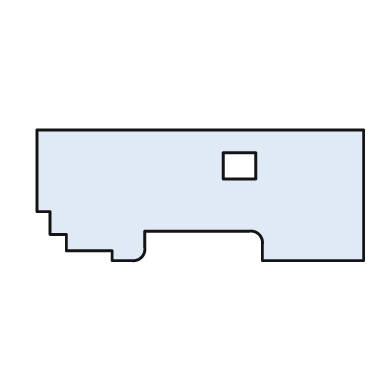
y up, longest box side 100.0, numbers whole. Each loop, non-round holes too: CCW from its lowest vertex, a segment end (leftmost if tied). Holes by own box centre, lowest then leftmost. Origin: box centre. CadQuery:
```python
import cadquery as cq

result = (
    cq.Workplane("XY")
    .moveTo(-27.0, -20.0)
    .lineTo(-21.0, -20.0)
    .threePointArc((-18.0, -19.0), (-17.0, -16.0))
    .lineTo(-17.0, -11.0)
    .lineTo(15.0, -11.0)
    .threePointArc((18.0, -12.0), (19.0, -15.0))
    .lineTo(19.0, -20.0)
    .lineTo(50.0, -20.0)
    .lineTo(50.0, 20.0)
    .lineTo(-50.0, 20.0)
    .lineTo(-50.0, -5.0)
    .lineTo(-46.0, -5.0)
    .lineTo(-46.0, -12.0)
    .lineTo(-41.0, -12.0)
    .lineTo(-41.0, -17.0)
    .lineTo(-27.0, -17.0)
    .close()
    .moveTo(7.0, 5.0)
    .lineTo(17.0, 5.0)
    .lineTo(17.0, 13.0)
    .lineTo(7.0, 13.0)
    .close()
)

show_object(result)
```